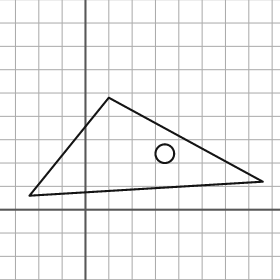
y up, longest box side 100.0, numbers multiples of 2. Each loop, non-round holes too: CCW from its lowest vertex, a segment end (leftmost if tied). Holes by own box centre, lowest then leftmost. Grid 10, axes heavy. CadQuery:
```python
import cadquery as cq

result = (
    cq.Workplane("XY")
    .moveTo(-24.0, 6.0)
    .lineTo(76.0, 12.0)
    .lineTo(10.0, 48.0)
    .close()
    .moveTo(34.0, 24.0)
    .circle(4.0)
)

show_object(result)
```